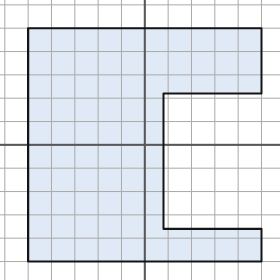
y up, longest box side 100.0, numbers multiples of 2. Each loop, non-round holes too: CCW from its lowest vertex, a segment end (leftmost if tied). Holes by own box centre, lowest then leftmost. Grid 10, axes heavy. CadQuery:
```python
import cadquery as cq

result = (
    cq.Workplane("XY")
    .moveTo(-50.0, -50.0)
    .lineTo(50.0, -50.0)
    .lineTo(50.0, -36.0)
    .lineTo(8.0, -36.0)
    .lineTo(8.0, 22.0)
    .lineTo(50.0, 22.0)
    .lineTo(50.0, 50.0)
    .lineTo(-50.0, 50.0)
    .close()
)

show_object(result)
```